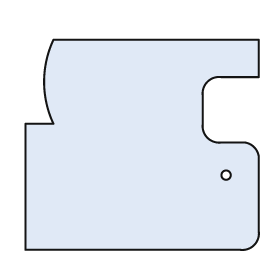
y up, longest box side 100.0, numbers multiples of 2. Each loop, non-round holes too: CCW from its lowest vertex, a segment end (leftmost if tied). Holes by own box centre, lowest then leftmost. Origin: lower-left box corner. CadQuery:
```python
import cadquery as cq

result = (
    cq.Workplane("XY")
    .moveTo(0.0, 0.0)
    .lineTo(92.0, 0.0)
    .threePointArc((98.0, 2.0), (100.0, 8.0))
    .lineTo(100.0, 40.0)
    .threePointArc((98.0, 44.0), (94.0, 46.0))
    .lineTo(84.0, 46.0)
    .threePointArc((78.0, 48.0), (76.0, 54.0))
    .lineTo(76.0, 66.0)
    .threePointArc((78.0, 72.0), (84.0, 74.0))
    .lineTo(100.0, 74.0)
    .lineTo(100.0, 90.0)
    .lineTo(12.0, 90.0)
    .threePointArc((8.0, 72.0), (12.0, 54.0))
    .lineTo(0.0, 54.0)
    .close()
    .moveTo(86.0, 32.0)
    .circle(2.0)
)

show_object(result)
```